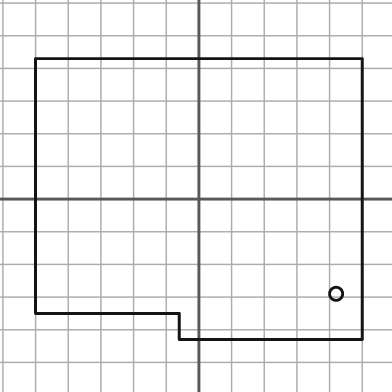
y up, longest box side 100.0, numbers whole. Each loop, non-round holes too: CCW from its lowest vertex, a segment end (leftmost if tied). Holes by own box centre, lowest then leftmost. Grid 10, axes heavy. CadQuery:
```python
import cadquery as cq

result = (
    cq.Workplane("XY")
    .moveTo(-6.0, -43.0)
    .lineTo(50.0, -43.0)
    .lineTo(50.0, 43.0)
    .lineTo(-50.0, 43.0)
    .lineTo(-50.0, -35.0)
    .lineTo(-6.0, -35.0)
    .close()
    .moveTo(42.0, -29.0)
    .circle(2.0)
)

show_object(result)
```